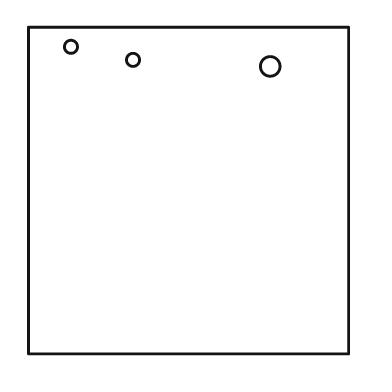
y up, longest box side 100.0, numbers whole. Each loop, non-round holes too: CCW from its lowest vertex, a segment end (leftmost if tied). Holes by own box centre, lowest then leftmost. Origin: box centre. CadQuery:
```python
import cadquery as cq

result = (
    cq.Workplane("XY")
    .moveTo(-49.0, -50.0)
    .lineTo(49.0, -50.0)
    .lineTo(49.0, 50.0)
    .lineTo(-49.0, 50.0)
    .close()
    .moveTo(25.0, 38.0)
    .circle(3.0)
    .moveTo(-17.0, 40.0)
    .circle(2.0)
    .moveTo(-36.0, 44.0)
    .circle(2.0)
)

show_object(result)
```